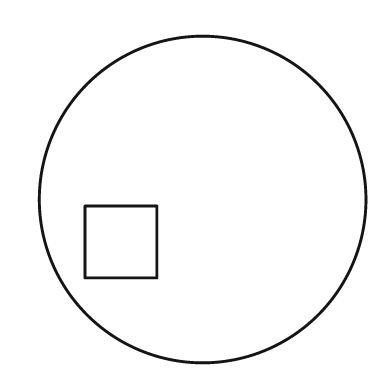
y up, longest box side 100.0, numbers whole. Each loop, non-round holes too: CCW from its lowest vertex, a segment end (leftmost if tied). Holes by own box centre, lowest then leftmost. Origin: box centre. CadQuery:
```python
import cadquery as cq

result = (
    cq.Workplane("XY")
    .moveTo(0.0, 0.0)
    .circle(50.0)
    .moveTo(-36.0, -24.0)
    .lineTo(-14.0, -24.0)
    .lineTo(-14.0, -2.0)
    .lineTo(-36.0, -2.0)
    .close()
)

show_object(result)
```